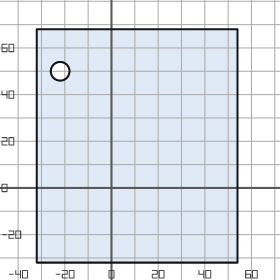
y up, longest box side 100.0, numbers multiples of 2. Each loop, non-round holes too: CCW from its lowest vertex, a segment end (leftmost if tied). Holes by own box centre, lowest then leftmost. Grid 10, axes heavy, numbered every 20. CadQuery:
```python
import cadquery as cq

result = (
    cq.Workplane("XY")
    .moveTo(-32.0, -32.0)
    .lineTo(54.0, -32.0)
    .lineTo(54.0, 68.0)
    .lineTo(-32.0, 68.0)
    .close()
    .moveTo(-22.0, 50.0)
    .circle(4.0)
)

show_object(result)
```